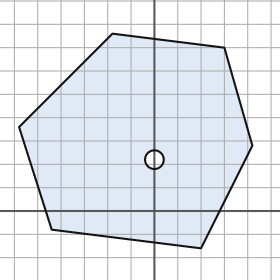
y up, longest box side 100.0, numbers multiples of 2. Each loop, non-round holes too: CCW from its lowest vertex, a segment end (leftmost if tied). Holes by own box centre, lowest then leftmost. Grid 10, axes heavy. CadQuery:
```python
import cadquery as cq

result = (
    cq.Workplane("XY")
    .moveTo(20.0, -16.0)
    .lineTo(42.0, 28.0)
    .lineTo(30.0, 70.0)
    .lineTo(-18.0, 76.0)
    .lineTo(-58.0, 36.0)
    .lineTo(-44.0, -8.0)
    .close()
    .moveTo(0.0, 22.0)
    .circle(4.0)
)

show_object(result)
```